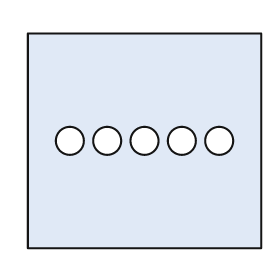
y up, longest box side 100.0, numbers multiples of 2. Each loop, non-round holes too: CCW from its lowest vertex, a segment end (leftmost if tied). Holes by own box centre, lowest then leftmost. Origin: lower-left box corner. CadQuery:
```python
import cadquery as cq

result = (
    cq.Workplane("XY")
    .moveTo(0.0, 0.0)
    .lineTo(100.0, 0.0)
    .lineTo(100.0, 92.0)
    .lineTo(0.0, 92.0)
    .close()
    .moveTo(18.0, 46.0)
    .circle(6.0)
    .moveTo(34.0, 46.0)
    .circle(6.0)
    .moveTo(50.0, 46.0)
    .circle(6.0)
    .moveTo(66.0, 46.0)
    .circle(6.0)
    .moveTo(82.0, 46.0)
    .circle(6.0)
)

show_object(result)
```